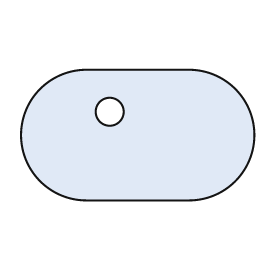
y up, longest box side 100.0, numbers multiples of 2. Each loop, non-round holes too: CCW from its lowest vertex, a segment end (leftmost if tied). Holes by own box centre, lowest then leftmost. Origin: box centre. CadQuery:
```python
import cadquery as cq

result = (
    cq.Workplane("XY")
    .moveTo(-22.0, -28.0)
    .lineTo(22.0, -28.0)
    .threePointArc((50.0, 0.0), (22.0, 28.0))
    .lineTo(-22.0, 28.0)
    .threePointArc((-50.0, 0.0), (-22.0, -28.0))
    .close()
    .moveTo(-12.0, 10.0)
    .circle(6.0)
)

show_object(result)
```